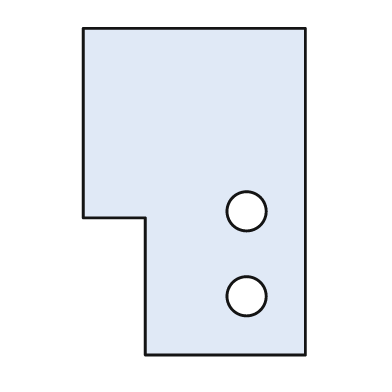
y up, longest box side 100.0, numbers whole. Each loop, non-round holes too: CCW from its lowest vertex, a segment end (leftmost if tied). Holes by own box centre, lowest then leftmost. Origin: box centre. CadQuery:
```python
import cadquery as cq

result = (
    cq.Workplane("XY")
    .moveTo(-15.0, -50.0)
    .lineTo(34.0, -50.0)
    .lineTo(34.0, 50.0)
    .lineTo(-34.0, 50.0)
    .lineTo(-34.0, -8.0)
    .lineTo(-15.0, -8.0)
    .close()
    .moveTo(16.0, -32.0)
    .circle(6.0)
    .moveTo(16.0, -6.0)
    .circle(6.0)
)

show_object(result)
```